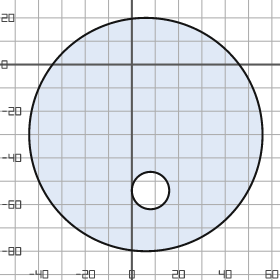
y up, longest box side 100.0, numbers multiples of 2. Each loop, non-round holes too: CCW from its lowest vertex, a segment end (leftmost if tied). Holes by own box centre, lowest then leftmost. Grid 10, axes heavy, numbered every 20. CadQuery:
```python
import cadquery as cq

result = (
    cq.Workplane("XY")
    .moveTo(6.0, -30.0)
    .circle(50.0)
    .moveTo(8.0, -54.0)
    .circle(8.0)
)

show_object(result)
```